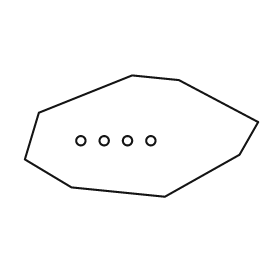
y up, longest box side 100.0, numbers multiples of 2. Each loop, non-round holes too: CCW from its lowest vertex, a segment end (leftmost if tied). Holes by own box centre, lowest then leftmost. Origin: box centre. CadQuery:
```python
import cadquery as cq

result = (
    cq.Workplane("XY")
    .moveTo(10.0, -26.0)
    .lineTo(42.0, -8.0)
    .lineTo(50.0, 6.0)
    .lineTo(16.0, 24.0)
    .lineTo(-4.0, 26.0)
    .lineTo(-44.0, 10.0)
    .lineTo(-50.0, -10.0)
    .lineTo(-30.0, -22.0)
    .close()
    .moveTo(-26.0, -2.0)
    .circle(2.0)
    .moveTo(-16.0, -2.0)
    .circle(2.0)
    .moveTo(-6.0, -2.0)
    .circle(2.0)
    .moveTo(4.0, -2.0)
    .circle(2.0)
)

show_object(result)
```